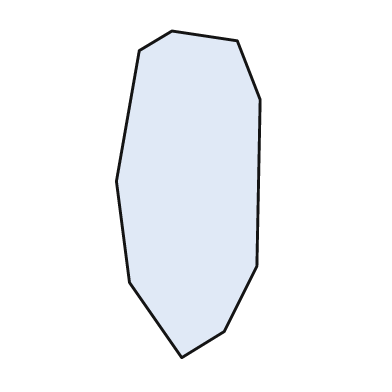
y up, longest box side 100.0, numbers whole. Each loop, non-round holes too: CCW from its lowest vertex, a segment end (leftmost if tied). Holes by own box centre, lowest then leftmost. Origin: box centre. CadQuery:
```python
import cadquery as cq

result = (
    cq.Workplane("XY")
    .moveTo(-2.0, -50.0)
    .lineTo(11.0, -42.0)
    .lineTo(21.0, -22.0)
    .lineTo(22.0, 29.0)
    .lineTo(15.0, 47.0)
    .lineTo(-5.0, 50.0)
    .lineTo(-15.0, 44.0)
    .lineTo(-22.0, 4.0)
    .lineTo(-18.0, -27.0)
    .close()
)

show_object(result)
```